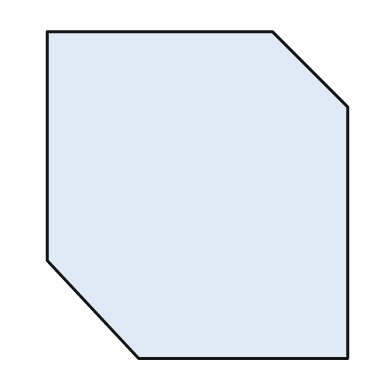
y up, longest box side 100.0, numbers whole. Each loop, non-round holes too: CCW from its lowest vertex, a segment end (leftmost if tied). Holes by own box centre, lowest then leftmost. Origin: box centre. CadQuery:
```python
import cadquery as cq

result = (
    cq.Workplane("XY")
    .moveTo(-18.0, -50.0)
    .lineTo(46.0, -50.0)
    .lineTo(46.0, 27.0)
    .lineTo(23.0, 50.0)
    .lineTo(-46.0, 50.0)
    .lineTo(-46.0, -20.0)
    .close()
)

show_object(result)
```